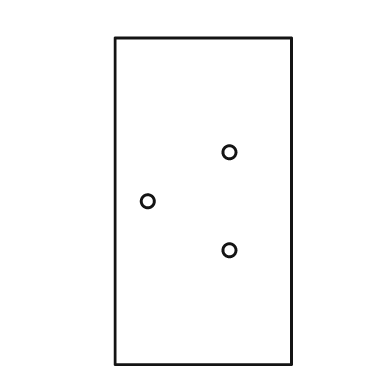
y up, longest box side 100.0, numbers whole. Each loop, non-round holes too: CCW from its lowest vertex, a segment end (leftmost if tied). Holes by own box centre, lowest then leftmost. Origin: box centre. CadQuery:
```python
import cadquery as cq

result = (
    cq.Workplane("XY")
    .moveTo(-27.0, -50.0)
    .lineTo(27.0, -50.0)
    .lineTo(27.0, 50.0)
    .lineTo(-27.0, 50.0)
    .close()
    .moveTo(8.0, -15.0)
    .circle(2.0)
    .moveTo(-17.0, 0.0)
    .circle(2.0)
    .moveTo(8.0, 15.0)
    .circle(2.0)
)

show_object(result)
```